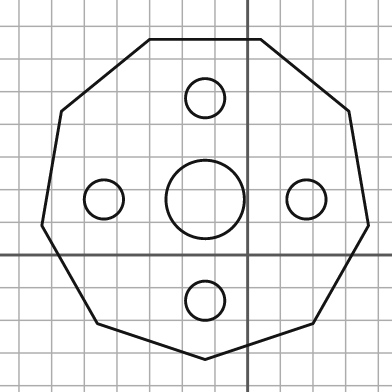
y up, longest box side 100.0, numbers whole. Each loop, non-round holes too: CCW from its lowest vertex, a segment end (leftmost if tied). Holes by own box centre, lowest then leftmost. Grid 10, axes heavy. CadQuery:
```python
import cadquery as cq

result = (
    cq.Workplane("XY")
    .moveTo(-13.0, -32.0)
    .lineTo(20.0, -21.0)
    .lineTo(37.0, 9.0)
    .lineTo(31.0, 44.0)
    .lineTo(4.0, 66.0)
    .lineTo(-30.0, 66.0)
    .lineTo(-57.0, 44.0)
    .lineTo(-63.0, 9.0)
    .lineTo(-46.0, -21.0)
    .close()
    .moveTo(-13.0, -14.0)
    .circle(6.0)
    .moveTo(-44.0, 17.0)
    .circle(6.0)
    .moveTo(-13.0, 17.0)
    .circle(12.0)
    .moveTo(18.0, 17.0)
    .circle(6.0)
    .moveTo(-13.0, 48.0)
    .circle(6.0)
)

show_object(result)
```